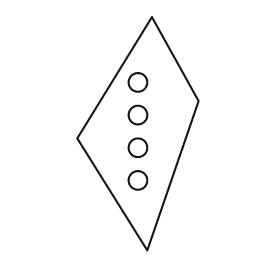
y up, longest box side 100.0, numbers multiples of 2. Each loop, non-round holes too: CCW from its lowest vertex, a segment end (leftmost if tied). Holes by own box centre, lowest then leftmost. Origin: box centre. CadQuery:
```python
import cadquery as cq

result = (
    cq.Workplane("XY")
    .moveTo(4.0, -50.0)
    .lineTo(26.0, 14.0)
    .lineTo(6.0, 50.0)
    .lineTo(-26.0, -2.0)
    .close()
    .moveTo(0.0, -20.0)
    .circle(4.0)
    .moveTo(0.0, -6.0)
    .circle(4.0)
    .moveTo(0.0, 8.0)
    .circle(4.0)
    .moveTo(0.0, 22.0)
    .circle(4.0)
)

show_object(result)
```